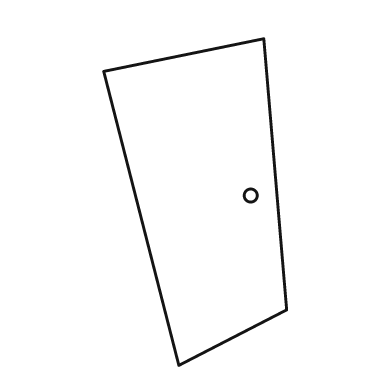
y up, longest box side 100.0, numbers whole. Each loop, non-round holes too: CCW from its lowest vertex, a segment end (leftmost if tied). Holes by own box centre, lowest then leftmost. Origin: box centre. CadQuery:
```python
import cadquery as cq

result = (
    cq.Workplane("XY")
    .moveTo(-5.0, -50.0)
    .lineTo(28.0, -33.0)
    .lineTo(21.0, 50.0)
    .lineTo(-28.0, 40.0)
    .close()
    .moveTo(17.0, 2.0)
    .circle(2.0)
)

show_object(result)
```